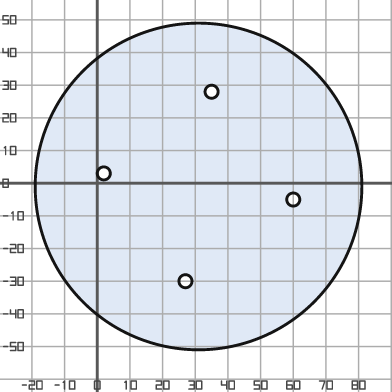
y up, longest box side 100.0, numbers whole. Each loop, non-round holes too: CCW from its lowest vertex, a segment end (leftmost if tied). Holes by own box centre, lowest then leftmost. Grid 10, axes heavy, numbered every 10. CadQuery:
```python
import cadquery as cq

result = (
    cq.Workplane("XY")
    .moveTo(31.0, -1.0)
    .circle(50.0)
    .moveTo(27.0, -30.0)
    .circle(2.0)
    .moveTo(60.0, -5.0)
    .circle(2.0)
    .moveTo(2.0, 3.0)
    .circle(2.0)
    .moveTo(35.0, 28.0)
    .circle(2.0)
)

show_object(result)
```